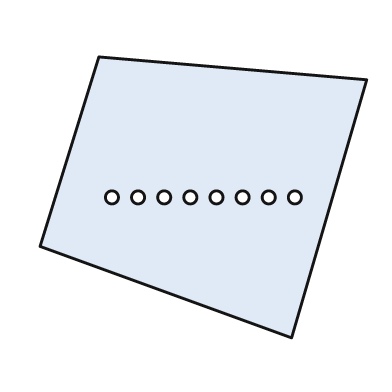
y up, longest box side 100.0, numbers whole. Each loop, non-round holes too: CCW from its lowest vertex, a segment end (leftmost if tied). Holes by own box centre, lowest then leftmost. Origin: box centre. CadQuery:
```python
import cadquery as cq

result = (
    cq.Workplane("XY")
    .moveTo(27.0, -43.0)
    .lineTo(50.0, 36.0)
    .lineTo(-32.0, 43.0)
    .lineTo(-50.0, -15.0)
    .close()
    .moveTo(-28.0, 0.0)
    .circle(2.0)
    .moveTo(-20.0, 0.0)
    .circle(2.0)
    .moveTo(-12.0, 0.0)
    .circle(2.0)
    .moveTo(-4.0, 0.0)
    .circle(2.0)
    .moveTo(4.0, 0.0)
    .circle(2.0)
    .moveTo(12.0, 0.0)
    .circle(2.0)
    .moveTo(20.0, 0.0)
    .circle(2.0)
    .moveTo(28.0, 0.0)
    .circle(2.0)
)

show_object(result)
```